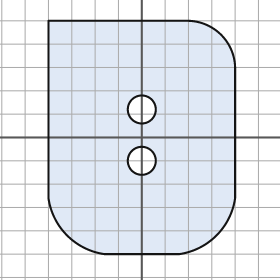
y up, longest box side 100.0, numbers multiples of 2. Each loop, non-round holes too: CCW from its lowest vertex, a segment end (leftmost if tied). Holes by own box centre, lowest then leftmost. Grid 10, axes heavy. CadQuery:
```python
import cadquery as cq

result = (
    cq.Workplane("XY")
    .moveTo(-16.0, -50.0)
    .lineTo(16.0, -50.0)
    .threePointArc((32.0, -42.0), (40.0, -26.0))
    .lineTo(40.0, 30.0)
    .threePointArc((34.0, 44.0), (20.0, 50.0))
    .lineTo(-40.0, 50.0)
    .lineTo(-40.0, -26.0)
    .threePointArc((-32.0, -42.0), (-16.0, -50.0))
    .close()
    .moveTo(0.0, -10.0)
    .circle(6.0)
    .moveTo(0.0, 12.0)
    .circle(6.0)
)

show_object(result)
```